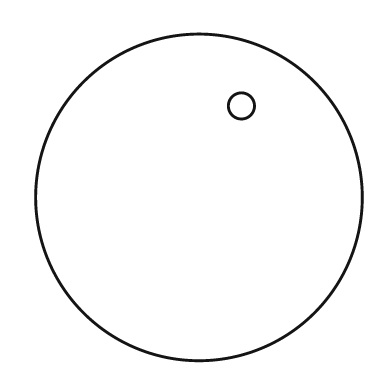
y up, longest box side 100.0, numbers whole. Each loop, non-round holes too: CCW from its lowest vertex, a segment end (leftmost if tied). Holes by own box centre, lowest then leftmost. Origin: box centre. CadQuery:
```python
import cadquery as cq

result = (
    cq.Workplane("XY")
    .moveTo(0.0, 0.0)
    .circle(50.0)
    .moveTo(13.0, 28.0)
    .circle(4.0)
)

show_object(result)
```